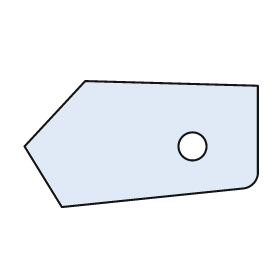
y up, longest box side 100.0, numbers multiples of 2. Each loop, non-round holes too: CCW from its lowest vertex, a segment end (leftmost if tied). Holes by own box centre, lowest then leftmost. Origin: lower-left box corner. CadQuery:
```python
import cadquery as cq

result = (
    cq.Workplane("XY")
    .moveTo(16.0, 0.0)
    .lineTo(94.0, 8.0)
    .threePointArc((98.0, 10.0), (100.0, 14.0))
    .lineTo(100.0, 52.0)
    .lineTo(26.0, 54.0)
    .lineTo(0.0, 26.0)
    .close()
    .moveTo(72.0, 26.0)
    .circle(6.0)
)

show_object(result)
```